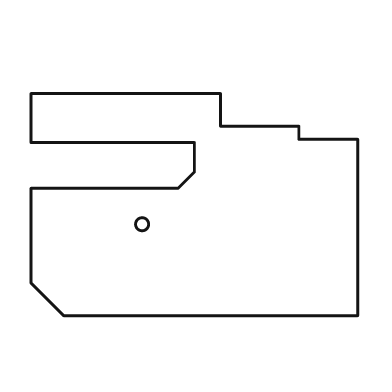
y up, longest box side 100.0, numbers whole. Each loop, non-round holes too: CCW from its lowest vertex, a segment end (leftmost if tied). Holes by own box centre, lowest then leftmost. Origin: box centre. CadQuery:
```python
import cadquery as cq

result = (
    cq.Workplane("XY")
    .moveTo(-40.0, -34.0)
    .lineTo(50.0, -34.0)
    .lineTo(50.0, 20.0)
    .lineTo(32.0, 20.0)
    .lineTo(32.0, 24.0)
    .lineTo(8.0, 24.0)
    .lineTo(8.0, 34.0)
    .lineTo(-50.0, 34.0)
    .lineTo(-50.0, 19.0)
    .lineTo(0.0, 19.0)
    .lineTo(0.0, 10.0)
    .lineTo(-5.0, 5.0)
    .lineTo(-50.0, 5.0)
    .lineTo(-50.0, -24.0)
    .close()
    .moveTo(-16.0, -6.0)
    .circle(2.0)
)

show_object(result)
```